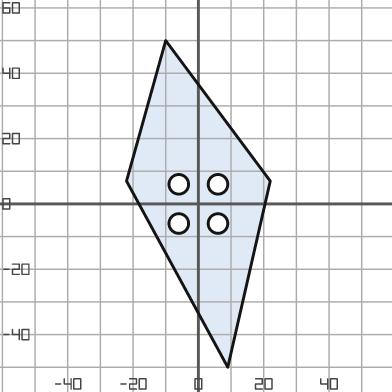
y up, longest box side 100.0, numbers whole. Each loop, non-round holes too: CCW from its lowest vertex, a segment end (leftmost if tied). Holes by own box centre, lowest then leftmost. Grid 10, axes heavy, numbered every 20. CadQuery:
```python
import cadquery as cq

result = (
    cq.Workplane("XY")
    .moveTo(9.0, -50.0)
    .lineTo(22.0, 7.0)
    .lineTo(-10.0, 50.0)
    .lineTo(-22.0, 7.0)
    .close()
    .moveTo(-6.0, -6.0)
    .circle(3.0)
    .moveTo(6.0, -6.0)
    .circle(3.0)
    .moveTo(-6.0, 6.0)
    .circle(3.0)
    .moveTo(6.0, 6.0)
    .circle(3.0)
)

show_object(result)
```